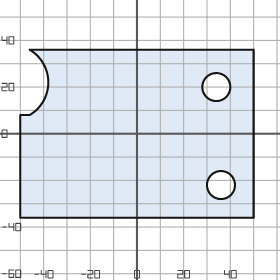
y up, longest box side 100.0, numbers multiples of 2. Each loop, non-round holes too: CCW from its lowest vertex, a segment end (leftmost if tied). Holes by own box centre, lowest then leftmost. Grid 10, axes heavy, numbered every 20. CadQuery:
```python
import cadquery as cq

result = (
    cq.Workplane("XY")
    .moveTo(-50.0, -36.0)
    .lineTo(50.0, -36.0)
    .lineTo(50.0, 36.0)
    .lineTo(-46.0, 36.0)
    .threePointArc((-38.0, 22.0), (-46.0, 8.0))
    .lineTo(-50.0, 8.0)
    .close()
    .moveTo(36.0, -22.0)
    .circle(6.0)
    .moveTo(34.0, 20.0)
    .circle(6.0)
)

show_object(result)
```